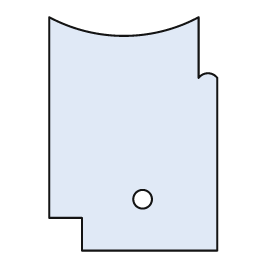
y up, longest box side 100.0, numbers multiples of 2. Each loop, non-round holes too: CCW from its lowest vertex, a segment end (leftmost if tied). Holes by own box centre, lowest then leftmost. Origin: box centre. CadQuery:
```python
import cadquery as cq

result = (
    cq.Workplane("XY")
    .moveTo(-22.0, -50.0)
    .lineTo(36.0, -50.0)
    .lineTo(36.0, 24.0)
    .threePointArc((32.0, 26.0), (28.0, 24.0))
    .lineTo(28.0, 50.0)
    .threePointArc((-4.0, 42.0), (-36.0, 50.0))
    .lineTo(-36.0, -36.0)
    .lineTo(-22.0, -36.0)
    .close()
    .moveTo(4.0, -28.0)
    .circle(4.0)
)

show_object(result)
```